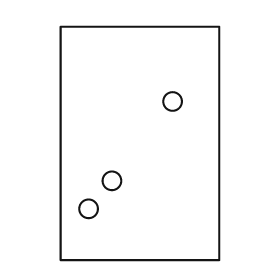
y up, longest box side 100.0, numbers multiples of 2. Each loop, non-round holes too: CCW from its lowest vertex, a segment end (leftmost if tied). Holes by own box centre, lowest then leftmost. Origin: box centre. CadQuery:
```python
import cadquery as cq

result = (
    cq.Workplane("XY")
    .moveTo(-34.0, -50.0)
    .lineTo(34.0, -50.0)
    .lineTo(34.0, 50.0)
    .lineTo(-34.0, 50.0)
    .close()
    .moveTo(-22.0, -28.0)
    .circle(4.0)
    .moveTo(-12.0, -16.0)
    .circle(4.0)
    .moveTo(14.0, 18.0)
    .circle(4.0)
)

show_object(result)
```